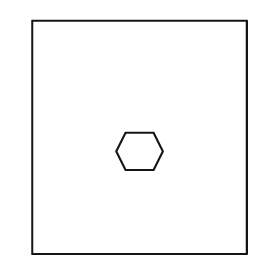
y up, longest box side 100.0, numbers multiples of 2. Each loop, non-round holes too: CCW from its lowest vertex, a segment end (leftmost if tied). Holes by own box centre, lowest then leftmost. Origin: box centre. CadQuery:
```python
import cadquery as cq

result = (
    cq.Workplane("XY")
    .moveTo(-46.0, -50.0)
    .lineTo(46.0, -50.0)
    .lineTo(46.0, 50.0)
    .lineTo(-46.0, 50.0)
    .close()
    .moveTo(-6.0, -14.0)
    .lineTo(6.0, -14.0)
    .lineTo(10.0, -6.0)
    .lineTo(6.0, 2.0)
    .lineTo(-6.0, 2.0)
    .lineTo(-10.0, -6.0)
    .close()
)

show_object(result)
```